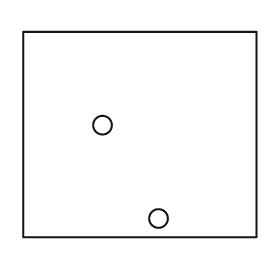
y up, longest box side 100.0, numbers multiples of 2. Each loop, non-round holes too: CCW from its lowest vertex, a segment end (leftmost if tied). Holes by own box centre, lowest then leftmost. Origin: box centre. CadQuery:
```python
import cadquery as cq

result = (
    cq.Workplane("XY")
    .moveTo(-50.0, -44.0)
    .lineTo(50.0, -44.0)
    .lineTo(50.0, 44.0)
    .lineTo(-50.0, 44.0)
    .close()
    .moveTo(8.0, -36.0)
    .circle(4.0)
    .moveTo(-16.0, 4.0)
    .circle(4.0)
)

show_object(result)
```